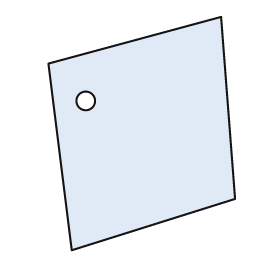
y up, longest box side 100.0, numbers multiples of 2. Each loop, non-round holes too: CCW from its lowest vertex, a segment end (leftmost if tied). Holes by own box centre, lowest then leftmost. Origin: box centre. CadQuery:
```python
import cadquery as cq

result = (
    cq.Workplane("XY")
    .moveTo(-30.0, -50.0)
    .lineTo(40.0, -28.0)
    .lineTo(34.0, 50.0)
    .lineTo(-40.0, 30.0)
    .close()
    .moveTo(-24.0, 14.0)
    .circle(4.0)
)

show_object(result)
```